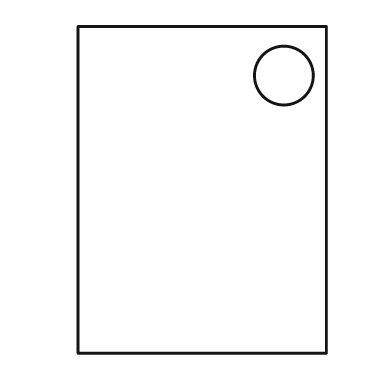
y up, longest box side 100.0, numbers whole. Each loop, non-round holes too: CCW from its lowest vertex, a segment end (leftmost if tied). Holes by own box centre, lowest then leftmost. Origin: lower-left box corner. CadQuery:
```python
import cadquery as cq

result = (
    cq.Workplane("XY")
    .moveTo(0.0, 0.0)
    .lineTo(76.0, 0.0)
    .lineTo(76.0, 100.0)
    .lineTo(0.0, 100.0)
    .close()
    .moveTo(63.0, 85.0)
    .circle(9.0)
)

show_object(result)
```